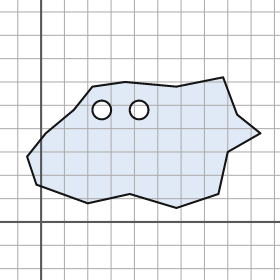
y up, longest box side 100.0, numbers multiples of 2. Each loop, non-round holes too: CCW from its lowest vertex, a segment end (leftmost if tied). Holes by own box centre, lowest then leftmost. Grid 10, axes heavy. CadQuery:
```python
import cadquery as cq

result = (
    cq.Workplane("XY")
    .moveTo(58.0, 6.0)
    .lineTo(76.0, 12.0)
    .lineTo(80.0, 30.0)
    .lineTo(94.0, 38.0)
    .lineTo(84.0, 46.0)
    .lineTo(78.0, 62.0)
    .lineTo(58.0, 58.0)
    .lineTo(36.0, 60.0)
    .lineTo(22.0, 58.0)
    .lineTo(14.0, 48.0)
    .lineTo(2.0, 38.0)
    .lineTo(-6.0, 28.0)
    .lineTo(-2.0, 16.0)
    .lineTo(20.0, 8.0)
    .lineTo(38.0, 12.0)
    .close()
    .moveTo(26.0, 48.0)
    .circle(4.0)
    .moveTo(42.0, 48.0)
    .circle(4.0)
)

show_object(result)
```